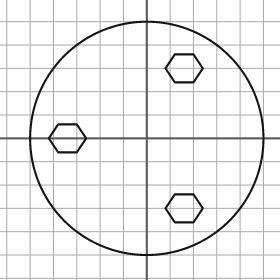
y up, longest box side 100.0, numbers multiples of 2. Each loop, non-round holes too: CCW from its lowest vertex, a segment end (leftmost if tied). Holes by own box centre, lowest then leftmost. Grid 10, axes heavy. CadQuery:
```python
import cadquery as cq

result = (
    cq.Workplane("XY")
    .moveTo(0.0, 0.0)
    .circle(50.0)
    .moveTo(12.0, -36.0)
    .lineTo(20.0, -36.0)
    .lineTo(24.0, -30.0)
    .lineTo(20.0, -24.0)
    .lineTo(12.0, -24.0)
    .lineTo(8.0, -30.0)
    .close()
    .moveTo(-38.0, -6.0)
    .lineTo(-30.0, -6.0)
    .lineTo(-26.0, 0.0)
    .lineTo(-30.0, 6.0)
    .lineTo(-38.0, 6.0)
    .lineTo(-42.0, 0.0)
    .close()
    .moveTo(12.0, 24.0)
    .lineTo(20.0, 24.0)
    .lineTo(24.0, 30.0)
    .lineTo(20.0, 36.0)
    .lineTo(12.0, 36.0)
    .lineTo(8.0, 30.0)
    .close()
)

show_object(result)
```